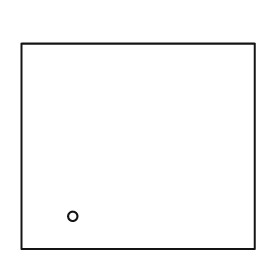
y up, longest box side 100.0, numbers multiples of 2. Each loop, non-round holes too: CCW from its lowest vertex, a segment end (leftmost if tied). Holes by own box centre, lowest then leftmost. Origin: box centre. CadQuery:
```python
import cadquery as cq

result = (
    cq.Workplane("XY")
    .moveTo(-50.0, -44.0)
    .lineTo(50.0, -44.0)
    .lineTo(50.0, 44.0)
    .lineTo(-50.0, 44.0)
    .close()
    .moveTo(-28.0, -30.0)
    .circle(2.0)
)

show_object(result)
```